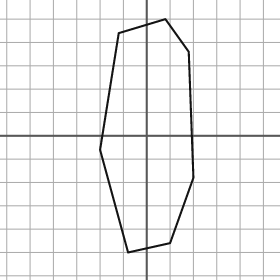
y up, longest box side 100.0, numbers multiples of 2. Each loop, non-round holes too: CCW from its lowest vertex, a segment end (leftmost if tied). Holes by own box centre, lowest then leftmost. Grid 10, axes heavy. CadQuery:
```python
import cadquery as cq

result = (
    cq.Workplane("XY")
    .moveTo(-8.0, -50.0)
    .lineTo(10.0, -46.0)
    .lineTo(20.0, -18.0)
    .lineTo(18.0, 36.0)
    .lineTo(8.0, 50.0)
    .lineTo(-12.0, 44.0)
    .lineTo(-20.0, -6.0)
    .close()
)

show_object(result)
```